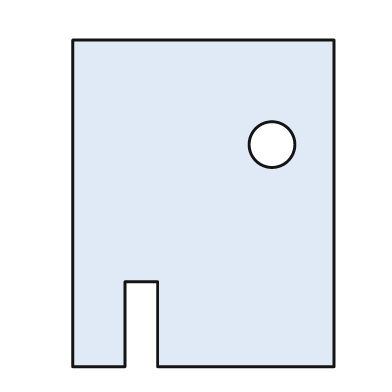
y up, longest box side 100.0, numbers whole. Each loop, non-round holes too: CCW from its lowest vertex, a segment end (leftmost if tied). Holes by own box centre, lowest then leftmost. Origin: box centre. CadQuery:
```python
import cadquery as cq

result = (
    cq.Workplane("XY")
    .moveTo(-40.0, -50.0)
    .lineTo(-24.0, -50.0)
    .lineTo(-24.0, -24.0)
    .lineTo(-14.0, -24.0)
    .lineTo(-14.0, -50.0)
    .lineTo(40.0, -50.0)
    .lineTo(40.0, 50.0)
    .lineTo(-40.0, 50.0)
    .close()
    .moveTo(21.0, 18.0)
    .circle(7.0)
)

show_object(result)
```